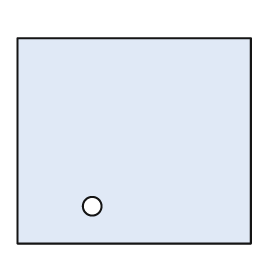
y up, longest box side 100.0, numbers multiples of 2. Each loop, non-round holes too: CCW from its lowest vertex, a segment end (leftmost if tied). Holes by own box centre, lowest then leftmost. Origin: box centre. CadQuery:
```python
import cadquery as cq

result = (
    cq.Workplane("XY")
    .moveTo(-50.0, -44.0)
    .lineTo(50.0, -44.0)
    .lineTo(50.0, 44.0)
    .lineTo(-50.0, 44.0)
    .close()
    .moveTo(-18.0, -28.0)
    .circle(4.0)
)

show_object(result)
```